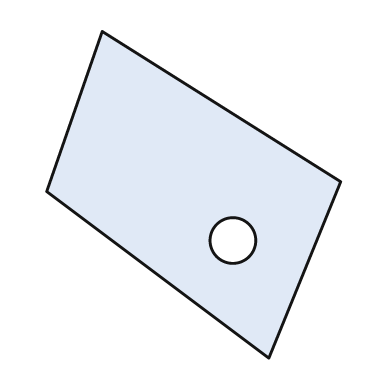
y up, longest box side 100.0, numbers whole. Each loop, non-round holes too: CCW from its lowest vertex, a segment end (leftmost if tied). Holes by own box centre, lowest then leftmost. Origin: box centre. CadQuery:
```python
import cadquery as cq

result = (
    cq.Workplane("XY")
    .moveTo(23.0, -50.0)
    .lineTo(45.0, 4.0)
    .lineTo(-28.0, 50.0)
    .lineTo(-45.0, 1.0)
    .close()
    .moveTo(12.0, -14.0)
    .circle(7.0)
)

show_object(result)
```